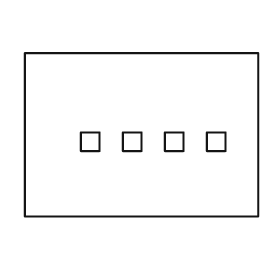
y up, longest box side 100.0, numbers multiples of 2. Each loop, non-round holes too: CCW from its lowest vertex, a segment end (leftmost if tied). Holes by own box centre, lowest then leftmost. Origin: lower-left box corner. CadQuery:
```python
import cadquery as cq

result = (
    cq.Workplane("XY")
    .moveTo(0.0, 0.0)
    .lineTo(100.0, 0.0)
    .lineTo(100.0, 70.0)
    .lineTo(0.0, 70.0)
    .close()
    .moveTo(24.0, 28.0)
    .lineTo(32.0, 28.0)
    .lineTo(32.0, 36.0)
    .lineTo(24.0, 36.0)
    .close()
    .moveTo(42.0, 28.0)
    .lineTo(50.0, 28.0)
    .lineTo(50.0, 36.0)
    .lineTo(42.0, 36.0)
    .close()
    .moveTo(60.0, 28.0)
    .lineTo(68.0, 28.0)
    .lineTo(68.0, 36.0)
    .lineTo(60.0, 36.0)
    .close()
    .moveTo(78.0, 28.0)
    .lineTo(86.0, 28.0)
    .lineTo(86.0, 36.0)
    .lineTo(78.0, 36.0)
    .close()
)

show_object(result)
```